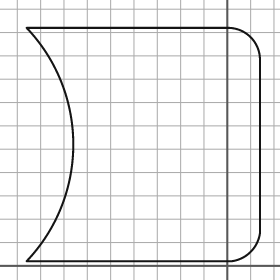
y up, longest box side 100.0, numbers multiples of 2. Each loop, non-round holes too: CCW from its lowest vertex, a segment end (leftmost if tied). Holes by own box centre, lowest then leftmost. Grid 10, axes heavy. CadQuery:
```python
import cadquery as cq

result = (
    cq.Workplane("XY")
    .moveTo(-86.0, 2.0)
    .lineTo(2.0, 2.0)
    .threePointArc((10.0, 6.0), (14.0, 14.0))
    .lineTo(14.0, 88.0)
    .threePointArc((10.0, 98.0), (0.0, 102.0))
    .lineTo(-86.0, 102.0)
    .threePointArc((-66.0, 52.0), (-86.0, 2.0))
    .close()
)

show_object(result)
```